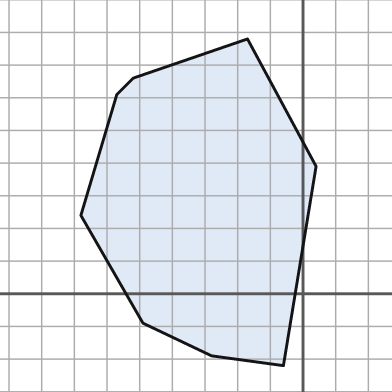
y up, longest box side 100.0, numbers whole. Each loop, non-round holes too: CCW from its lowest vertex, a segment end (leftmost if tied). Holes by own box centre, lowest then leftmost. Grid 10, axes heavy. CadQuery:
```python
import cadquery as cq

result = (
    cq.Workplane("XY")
    .moveTo(-6.0, -22.0)
    .lineTo(4.0, 39.0)
    .lineTo(-17.0, 78.0)
    .lineTo(-52.0, 66.0)
    .lineTo(-57.0, 61.0)
    .lineTo(-68.0, 24.0)
    .lineTo(-49.0, -9.0)
    .lineTo(-28.0, -19.0)
    .close()
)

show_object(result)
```